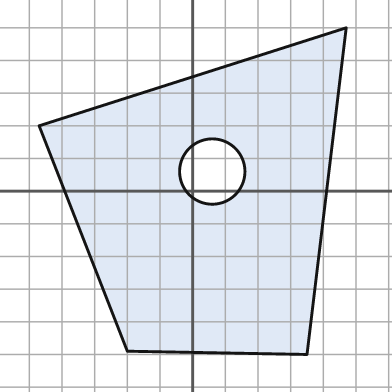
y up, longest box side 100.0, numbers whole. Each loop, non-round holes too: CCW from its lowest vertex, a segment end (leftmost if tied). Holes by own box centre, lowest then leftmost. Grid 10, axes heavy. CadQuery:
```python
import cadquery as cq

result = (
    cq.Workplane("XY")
    .moveTo(35.0, -50.0)
    .lineTo(47.0, 50.0)
    .lineTo(-47.0, 20.0)
    .lineTo(-20.0, -49.0)
    .close()
    .moveTo(6.0, 6.0)
    .circle(10.0)
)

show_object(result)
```